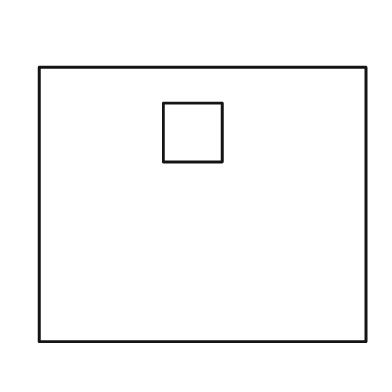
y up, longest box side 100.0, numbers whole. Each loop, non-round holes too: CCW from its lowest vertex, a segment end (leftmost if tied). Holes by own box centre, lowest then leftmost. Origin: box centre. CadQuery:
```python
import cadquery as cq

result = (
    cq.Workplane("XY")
    .moveTo(-50.0, -42.0)
    .lineTo(50.0, -42.0)
    .lineTo(50.0, 42.0)
    .lineTo(-50.0, 42.0)
    .close()
    .moveTo(-12.0, 13.0)
    .lineTo(6.0, 13.0)
    .lineTo(6.0, 31.0)
    .lineTo(-12.0, 31.0)
    .close()
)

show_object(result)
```